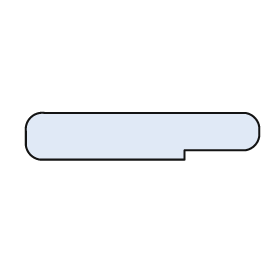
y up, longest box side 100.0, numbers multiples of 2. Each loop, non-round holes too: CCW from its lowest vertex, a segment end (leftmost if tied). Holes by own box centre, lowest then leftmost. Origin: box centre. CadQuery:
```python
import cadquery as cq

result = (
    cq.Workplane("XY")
    .moveTo(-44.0, -10.0)
    .lineTo(18.0, -10.0)
    .lineTo(18.0, -6.0)
    .lineTo(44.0, -6.0)
    .threePointArc((48.0, -4.0), (50.0, 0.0))
    .lineTo(50.0, 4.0)
    .threePointArc((48.0, 8.0), (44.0, 10.0))
    .lineTo(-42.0, 10.0)
    .threePointArc((-48.0, 8.0), (-50.0, 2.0))
    .lineTo(-50.0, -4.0)
    .threePointArc((-48.0, -8.0), (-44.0, -10.0))
    .close()
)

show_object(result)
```